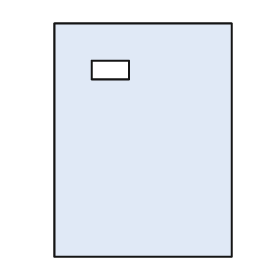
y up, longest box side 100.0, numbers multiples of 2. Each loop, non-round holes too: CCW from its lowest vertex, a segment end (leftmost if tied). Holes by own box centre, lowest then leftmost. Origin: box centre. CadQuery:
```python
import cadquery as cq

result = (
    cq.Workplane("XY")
    .moveTo(-38.0, -50.0)
    .lineTo(38.0, -50.0)
    .lineTo(38.0, 50.0)
    .lineTo(-38.0, 50.0)
    .close()
    .moveTo(-22.0, 26.0)
    .lineTo(-6.0, 26.0)
    .lineTo(-6.0, 34.0)
    .lineTo(-22.0, 34.0)
    .close()
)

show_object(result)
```